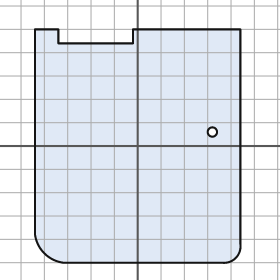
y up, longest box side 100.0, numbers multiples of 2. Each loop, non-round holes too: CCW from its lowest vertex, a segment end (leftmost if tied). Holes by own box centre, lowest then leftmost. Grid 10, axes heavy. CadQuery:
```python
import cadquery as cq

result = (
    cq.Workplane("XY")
    .moveTo(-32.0, -50.0)
    .lineTo(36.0, -50.0)
    .threePointArc((42.0, -48.0), (44.0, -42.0))
    .lineTo(44.0, 50.0)
    .lineTo(-2.0, 50.0)
    .lineTo(-2.0, 44.0)
    .lineTo(-34.0, 44.0)
    .lineTo(-34.0, 50.0)
    .lineTo(-44.0, 50.0)
    .lineTo(-44.0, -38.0)
    .threePointArc((-40.0, -46.0), (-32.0, -50.0))
    .close()
    .moveTo(32.0, 6.0)
    .circle(2.0)
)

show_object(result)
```